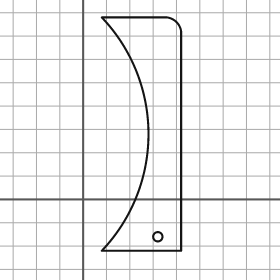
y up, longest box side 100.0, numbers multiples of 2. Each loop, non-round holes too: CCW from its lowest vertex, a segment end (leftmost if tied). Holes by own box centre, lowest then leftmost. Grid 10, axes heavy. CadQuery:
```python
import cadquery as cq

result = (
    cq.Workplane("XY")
    .moveTo(8.0, -22.0)
    .lineTo(42.0, -22.0)
    .lineTo(42.0, 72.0)
    .threePointArc((40.0, 76.0), (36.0, 78.0))
    .lineTo(8.0, 78.0)
    .threePointArc((28.0, 28.0), (8.0, -22.0))
    .close()
    .moveTo(32.0, -16.0)
    .circle(2.0)
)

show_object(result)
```